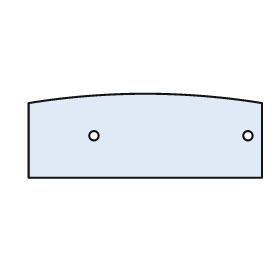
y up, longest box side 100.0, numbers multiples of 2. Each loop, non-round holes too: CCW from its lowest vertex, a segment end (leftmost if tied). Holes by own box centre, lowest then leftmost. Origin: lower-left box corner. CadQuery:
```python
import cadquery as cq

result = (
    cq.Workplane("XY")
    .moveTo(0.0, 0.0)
    .lineTo(100.0, 0.0)
    .lineTo(100.0, 32.0)
    .threePointArc((50.0, 36.0), (0.0, 32.0))
    .close()
    .moveTo(28.0, 18.0)
    .circle(2.0)
    .moveTo(94.0, 18.0)
    .circle(2.0)
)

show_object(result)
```